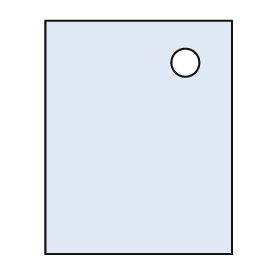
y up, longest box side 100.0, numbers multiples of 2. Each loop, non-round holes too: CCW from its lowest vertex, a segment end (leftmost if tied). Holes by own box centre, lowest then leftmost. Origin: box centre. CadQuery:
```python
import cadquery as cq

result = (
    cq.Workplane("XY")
    .moveTo(-40.0, -50.0)
    .lineTo(40.0, -50.0)
    .lineTo(40.0, 50.0)
    .lineTo(-40.0, 50.0)
    .close()
    .moveTo(20.0, 32.0)
    .circle(6.0)
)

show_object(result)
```